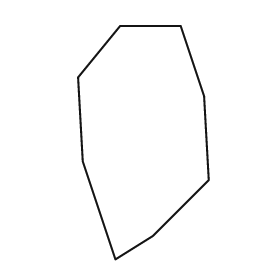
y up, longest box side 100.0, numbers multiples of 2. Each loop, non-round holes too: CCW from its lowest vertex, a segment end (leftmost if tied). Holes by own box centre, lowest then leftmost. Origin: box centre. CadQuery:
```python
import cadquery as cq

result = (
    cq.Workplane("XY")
    .moveTo(-12.0, -50.0)
    .lineTo(4.0, -40.0)
    .lineTo(28.0, -16.0)
    .lineTo(26.0, 20.0)
    .lineTo(16.0, 50.0)
    .lineTo(-10.0, 50.0)
    .lineTo(-28.0, 28.0)
    .lineTo(-26.0, -8.0)
    .close()
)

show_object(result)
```